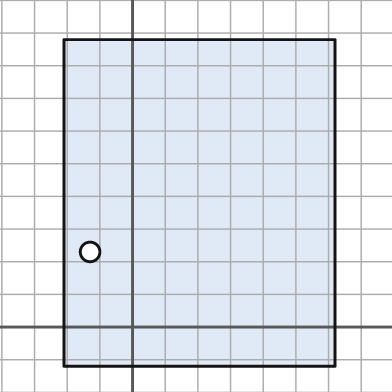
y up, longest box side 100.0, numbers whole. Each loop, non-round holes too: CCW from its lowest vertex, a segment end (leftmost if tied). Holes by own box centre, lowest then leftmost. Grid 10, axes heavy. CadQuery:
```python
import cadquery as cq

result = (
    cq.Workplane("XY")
    .moveTo(-21.0, -12.0)
    .lineTo(62.0, -12.0)
    .lineTo(62.0, 88.0)
    .lineTo(-21.0, 88.0)
    .close()
    .moveTo(-13.0, 23.0)
    .circle(3.0)
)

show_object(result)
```